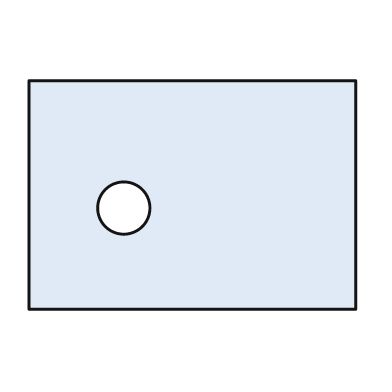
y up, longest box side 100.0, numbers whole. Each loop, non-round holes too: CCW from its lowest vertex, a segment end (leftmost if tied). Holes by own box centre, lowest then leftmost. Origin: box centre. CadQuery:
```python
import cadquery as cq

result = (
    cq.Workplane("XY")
    .moveTo(-50.0, -35.0)
    .lineTo(50.0, -35.0)
    .lineTo(50.0, 35.0)
    .lineTo(-50.0, 35.0)
    .close()
    .moveTo(-21.0, -4.0)
    .circle(8.0)
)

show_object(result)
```